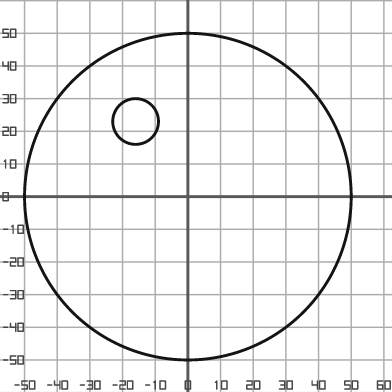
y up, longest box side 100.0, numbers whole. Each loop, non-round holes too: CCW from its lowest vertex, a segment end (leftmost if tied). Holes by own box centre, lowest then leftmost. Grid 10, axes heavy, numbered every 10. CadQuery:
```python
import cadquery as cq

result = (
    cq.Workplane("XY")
    .moveTo(0.0, 0.0)
    .circle(50.0)
    .moveTo(-16.0, 23.0)
    .circle(7.0)
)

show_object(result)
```